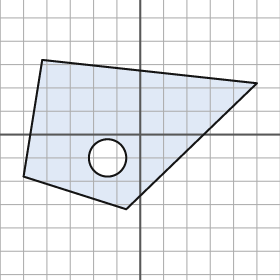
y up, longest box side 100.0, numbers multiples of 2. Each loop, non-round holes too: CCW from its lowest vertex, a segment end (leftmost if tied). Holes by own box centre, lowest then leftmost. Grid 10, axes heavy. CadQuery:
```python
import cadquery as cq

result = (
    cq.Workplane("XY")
    .moveTo(-6.0, -32.0)
    .lineTo(50.0, 22.0)
    .lineTo(-42.0, 32.0)
    .lineTo(-50.0, -18.0)
    .close()
    .moveTo(-14.0, -10.0)
    .circle(8.0)
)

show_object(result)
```